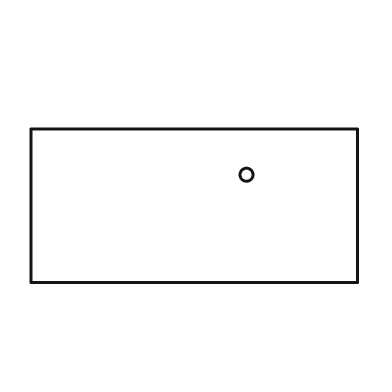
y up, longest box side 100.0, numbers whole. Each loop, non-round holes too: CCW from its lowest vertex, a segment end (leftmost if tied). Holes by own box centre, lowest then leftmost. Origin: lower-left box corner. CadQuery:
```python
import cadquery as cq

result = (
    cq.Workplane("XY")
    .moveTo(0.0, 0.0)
    .lineTo(100.0, 0.0)
    .lineTo(100.0, 47.0)
    .lineTo(0.0, 47.0)
    .close()
    .moveTo(66.0, 33.0)
    .circle(2.0)
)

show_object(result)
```